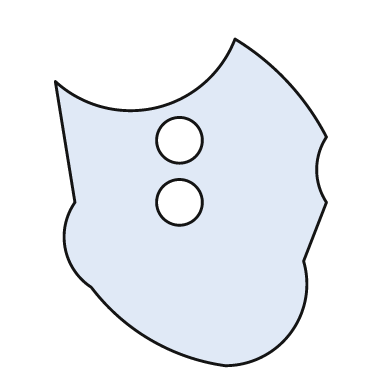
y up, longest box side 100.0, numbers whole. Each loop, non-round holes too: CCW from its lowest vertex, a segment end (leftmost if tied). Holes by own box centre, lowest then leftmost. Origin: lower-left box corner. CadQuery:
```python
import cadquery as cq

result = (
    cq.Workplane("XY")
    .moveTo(52.0, 0.0)
    .threePointArc((72.0, 10.0), (76.0, 32.0))
    .lineTo(83.0, 50.0)
    .threePointArc((80.0, 60.0), (83.0, 70.0))
    .threePointArc((71.0, 87.0), (55.0, 100.0))
    .threePointArc((31.0, 79.0), (0.0, 87.0))
    .lineTo(6.0, 50.0)
    .threePointArc((3.0, 36.0), (11.0, 24.0))
    .threePointArc((29.0, 8.0), (52.0, 0.0))
    .close()
    .moveTo(38.0, 50.0)
    .circle(7.0)
    .moveTo(38.0, 69.0)
    .circle(7.0)
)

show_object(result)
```